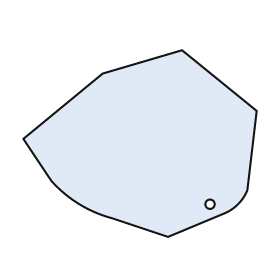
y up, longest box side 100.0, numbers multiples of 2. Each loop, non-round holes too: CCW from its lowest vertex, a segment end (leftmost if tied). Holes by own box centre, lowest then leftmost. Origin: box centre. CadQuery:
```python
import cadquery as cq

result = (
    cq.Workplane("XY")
    .moveTo(12.0, -40.0)
    .lineTo(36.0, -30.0)
    .threePointArc((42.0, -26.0), (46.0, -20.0))
    .lineTo(50.0, 14.0)
    .lineTo(18.0, 40.0)
    .lineTo(-16.0, 30.0)
    .lineTo(-50.0, 2.0)
    .lineTo(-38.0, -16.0)
    .threePointArc((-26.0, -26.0), (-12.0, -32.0))
    .close()
    .moveTo(30.0, -26.0)
    .circle(2.0)
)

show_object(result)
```